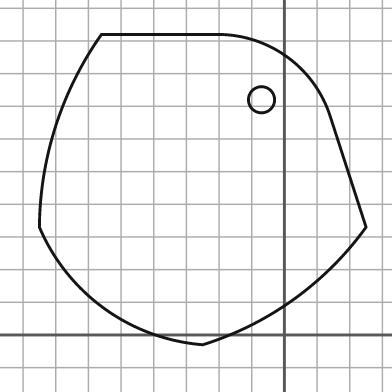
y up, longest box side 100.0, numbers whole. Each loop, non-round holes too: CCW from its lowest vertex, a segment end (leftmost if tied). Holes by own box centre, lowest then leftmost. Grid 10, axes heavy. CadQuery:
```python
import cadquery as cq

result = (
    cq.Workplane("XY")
    .moveTo(-25.0, -3.0)
    .threePointArc((3.0, 11.0), (25.0, 33.0))
    .lineTo(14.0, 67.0)
    .threePointArc((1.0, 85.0), (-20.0, 92.0))
    .lineTo(-56.0, 92.0)
    .threePointArc((-70.0, 64.0), (-75.0, 33.0))
    .threePointArc((-55.0, 8.0), (-25.0, -3.0))
    .close()
    .moveTo(-7.0, 72.0)
    .circle(4.0)
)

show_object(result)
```